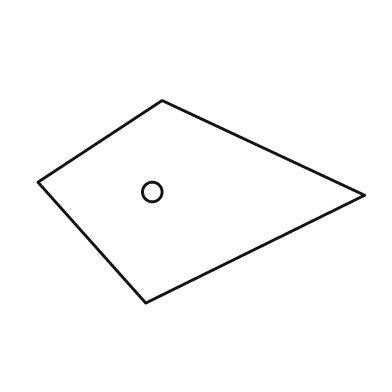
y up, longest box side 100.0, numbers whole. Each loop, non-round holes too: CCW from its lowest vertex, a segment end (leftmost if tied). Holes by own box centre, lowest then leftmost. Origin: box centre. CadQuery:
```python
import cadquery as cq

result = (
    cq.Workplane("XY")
    .moveTo(-17.0, -31.0)
    .lineTo(50.0, 2.0)
    .lineTo(-12.0, 31.0)
    .lineTo(-50.0, 6.0)
    .close()
    .moveTo(-15.0, 3.0)
    .circle(3.0)
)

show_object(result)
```